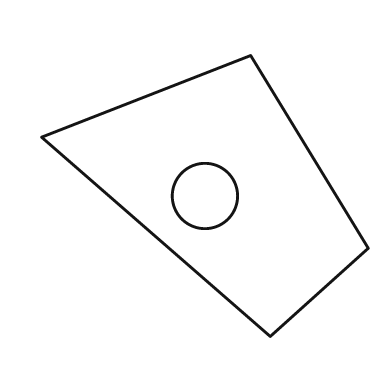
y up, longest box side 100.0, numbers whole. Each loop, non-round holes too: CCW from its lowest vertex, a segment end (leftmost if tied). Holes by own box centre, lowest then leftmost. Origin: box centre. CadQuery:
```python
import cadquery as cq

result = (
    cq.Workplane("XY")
    .moveTo(20.0, -43.0)
    .lineTo(50.0, -16.0)
    .lineTo(14.0, 43.0)
    .lineTo(-50.0, 18.0)
    .close()
    .moveTo(0.0, 0.0)
    .circle(10.0)
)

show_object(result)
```